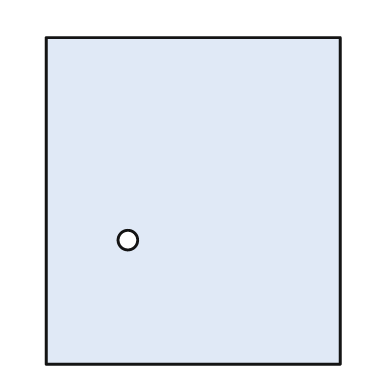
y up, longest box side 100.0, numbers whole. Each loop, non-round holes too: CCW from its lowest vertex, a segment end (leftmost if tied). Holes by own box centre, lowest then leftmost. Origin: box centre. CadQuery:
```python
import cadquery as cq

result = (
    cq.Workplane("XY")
    .moveTo(-45.0, -50.0)
    .lineTo(45.0, -50.0)
    .lineTo(45.0, 50.0)
    .lineTo(-45.0, 50.0)
    .close()
    .moveTo(-20.0, -12.0)
    .circle(3.0)
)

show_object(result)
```